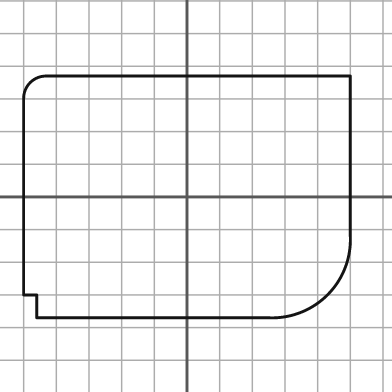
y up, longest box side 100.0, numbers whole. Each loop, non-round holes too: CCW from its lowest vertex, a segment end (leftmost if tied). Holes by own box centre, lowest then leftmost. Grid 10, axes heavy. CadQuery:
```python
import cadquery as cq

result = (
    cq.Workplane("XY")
    .moveTo(-46.0, -37.0)
    .lineTo(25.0, -37.0)
    .threePointArc((43.0, -30.0), (50.0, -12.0))
    .lineTo(50.0, 37.0)
    .lineTo(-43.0, 37.0)
    .threePointArc((-48.0, 35.0), (-50.0, 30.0))
    .lineTo(-50.0, -30.0)
    .lineTo(-46.0, -30.0)
    .close()
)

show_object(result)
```